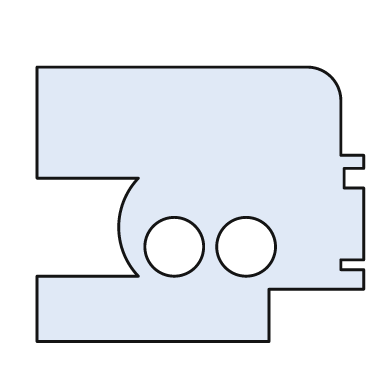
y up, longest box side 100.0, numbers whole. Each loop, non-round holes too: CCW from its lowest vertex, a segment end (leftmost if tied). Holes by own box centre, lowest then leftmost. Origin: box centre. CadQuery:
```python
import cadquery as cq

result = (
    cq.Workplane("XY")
    .moveTo(-50.0, -42.0)
    .lineTo(21.0, -42.0)
    .lineTo(21.0, -26.0)
    .lineTo(50.0, -26.0)
    .lineTo(50.0, -20.0)
    .lineTo(43.0, -20.0)
    .lineTo(43.0, -17.0)
    .lineTo(50.0, -17.0)
    .lineTo(50.0, 5.0)
    .lineTo(44.0, 5.0)
    .lineTo(44.0, 11.0)
    .lineTo(50.0, 11.0)
    .lineTo(50.0, 15.0)
    .lineTo(43.0, 15.0)
    .lineTo(43.0, 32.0)
    .threePointArc((40.0, 39.0), (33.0, 42.0))
    .lineTo(-50.0, 42.0)
    .lineTo(-50.0, 8.0)
    .lineTo(-19.0, 8.0)
    .threePointArc((-25.0, -7.0), (-19.0, -22.0))
    .lineTo(-50.0, -22.0)
    .close()
    .moveTo(-8.0, -13.0)
    .circle(9.0)
    .moveTo(14.0, -13.0)
    .circle(9.0)
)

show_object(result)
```